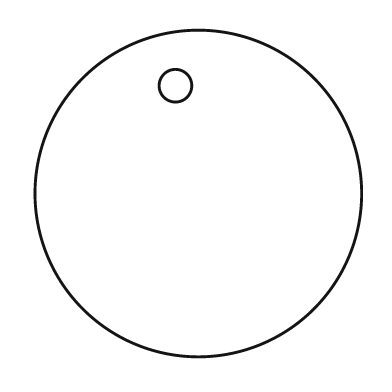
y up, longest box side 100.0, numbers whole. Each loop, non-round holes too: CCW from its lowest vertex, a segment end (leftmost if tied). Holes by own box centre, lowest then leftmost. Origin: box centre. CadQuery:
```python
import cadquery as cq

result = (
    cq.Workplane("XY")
    .moveTo(0.0, 0.0)
    .circle(50.0)
    .moveTo(-7.0, 33.0)
    .circle(5.0)
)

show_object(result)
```